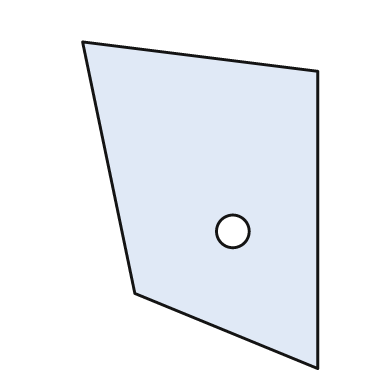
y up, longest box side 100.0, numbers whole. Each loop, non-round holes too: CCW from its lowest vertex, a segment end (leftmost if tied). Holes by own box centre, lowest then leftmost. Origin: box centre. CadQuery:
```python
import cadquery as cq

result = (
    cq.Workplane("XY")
    .moveTo(36.0, -50.0)
    .lineTo(36.0, 41.0)
    .lineTo(-36.0, 50.0)
    .lineTo(-20.0, -27.0)
    .close()
    .moveTo(10.0, -8.0)
    .circle(5.0)
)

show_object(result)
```